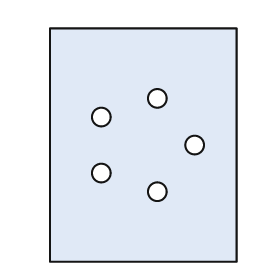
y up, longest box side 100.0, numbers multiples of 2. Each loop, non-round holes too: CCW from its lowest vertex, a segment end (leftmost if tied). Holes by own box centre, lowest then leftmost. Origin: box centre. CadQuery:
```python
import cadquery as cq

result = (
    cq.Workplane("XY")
    .moveTo(-40.0, -50.0)
    .lineTo(40.0, -50.0)
    .lineTo(40.0, 50.0)
    .lineTo(-40.0, 50.0)
    .close()
    .moveTo(6.0, -20.0)
    .circle(4.0)
    .moveTo(-18.0, -12.0)
    .circle(4.0)
    .moveTo(22.0, 0.0)
    .circle(4.0)
    .moveTo(-18.0, 12.0)
    .circle(4.0)
    .moveTo(6.0, 20.0)
    .circle(4.0)
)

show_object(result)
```